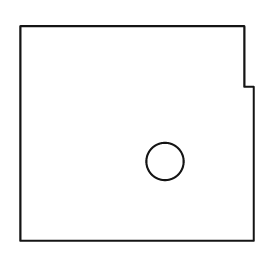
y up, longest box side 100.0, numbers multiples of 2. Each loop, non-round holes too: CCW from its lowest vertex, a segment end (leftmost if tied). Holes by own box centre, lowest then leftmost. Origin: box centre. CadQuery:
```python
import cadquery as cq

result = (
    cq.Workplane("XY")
    .moveTo(-50.0, -46.0)
    .lineTo(50.0, -46.0)
    .lineTo(50.0, 20.0)
    .lineTo(46.0, 20.0)
    .lineTo(46.0, 46.0)
    .lineTo(-50.0, 46.0)
    .close()
    .moveTo(12.0, -12.0)
    .circle(8.0)
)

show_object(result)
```